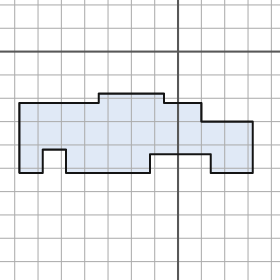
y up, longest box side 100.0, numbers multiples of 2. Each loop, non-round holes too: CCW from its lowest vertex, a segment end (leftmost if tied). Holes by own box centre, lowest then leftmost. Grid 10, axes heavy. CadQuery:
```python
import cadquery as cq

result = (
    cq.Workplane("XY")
    .moveTo(-68.0, -52.0)
    .lineTo(-58.0, -52.0)
    .lineTo(-58.0, -42.0)
    .lineTo(-48.0, -42.0)
    .lineTo(-48.0, -52.0)
    .lineTo(-12.0, -52.0)
    .lineTo(-12.0, -44.0)
    .lineTo(14.0, -44.0)
    .lineTo(14.0, -52.0)
    .lineTo(32.0, -52.0)
    .lineTo(32.0, -30.0)
    .lineTo(10.0, -30.0)
    .lineTo(10.0, -22.0)
    .lineTo(-6.0, -22.0)
    .lineTo(-6.0, -18.0)
    .lineTo(-34.0, -18.0)
    .lineTo(-34.0, -22.0)
    .lineTo(-68.0, -22.0)
    .close()
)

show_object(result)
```